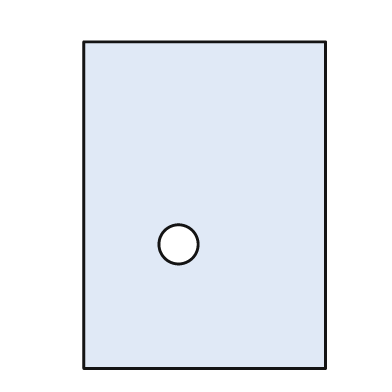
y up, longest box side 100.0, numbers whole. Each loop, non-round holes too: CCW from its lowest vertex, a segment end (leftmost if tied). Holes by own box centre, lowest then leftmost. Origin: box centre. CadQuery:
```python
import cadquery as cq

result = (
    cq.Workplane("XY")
    .moveTo(-37.0, -50.0)
    .lineTo(37.0, -50.0)
    .lineTo(37.0, 50.0)
    .lineTo(-37.0, 50.0)
    .close()
    .moveTo(-8.0, -12.0)
    .circle(6.0)
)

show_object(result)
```